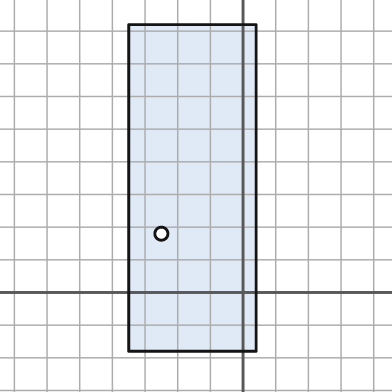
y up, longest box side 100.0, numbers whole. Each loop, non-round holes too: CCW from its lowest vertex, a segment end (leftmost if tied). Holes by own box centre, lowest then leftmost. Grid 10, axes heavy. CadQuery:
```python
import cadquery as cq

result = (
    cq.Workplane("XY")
    .moveTo(-35.0, -18.0)
    .lineTo(4.0, -18.0)
    .lineTo(4.0, 82.0)
    .lineTo(-35.0, 82.0)
    .close()
    .moveTo(-25.0, 18.0)
    .circle(2.0)
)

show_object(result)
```